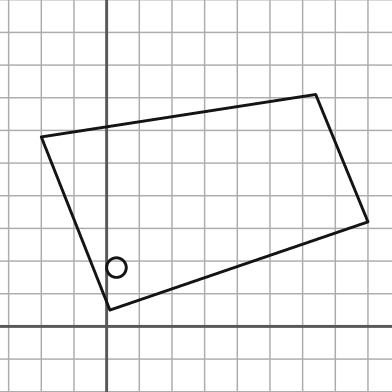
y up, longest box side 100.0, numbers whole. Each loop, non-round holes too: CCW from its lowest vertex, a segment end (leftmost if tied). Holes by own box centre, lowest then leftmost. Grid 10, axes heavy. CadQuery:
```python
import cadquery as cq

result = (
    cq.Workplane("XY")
    .moveTo(1.0, 5.0)
    .lineTo(80.0, 32.0)
    .lineTo(64.0, 71.0)
    .lineTo(-20.0, 58.0)
    .close()
    .moveTo(3.0, 18.0)
    .circle(3.0)
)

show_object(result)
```